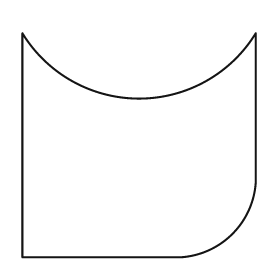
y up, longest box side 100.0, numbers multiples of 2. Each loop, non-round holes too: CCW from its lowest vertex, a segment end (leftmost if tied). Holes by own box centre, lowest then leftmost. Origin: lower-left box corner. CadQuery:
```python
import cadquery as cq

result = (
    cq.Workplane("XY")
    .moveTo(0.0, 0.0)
    .lineTo(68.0, 0.0)
    .threePointArc((90.0, 10.0), (100.0, 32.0))
    .lineTo(100.0, 96.0)
    .threePointArc((50.0, 68.0), (0.0, 96.0))
    .close()
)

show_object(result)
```